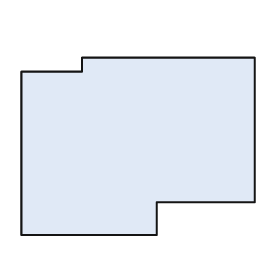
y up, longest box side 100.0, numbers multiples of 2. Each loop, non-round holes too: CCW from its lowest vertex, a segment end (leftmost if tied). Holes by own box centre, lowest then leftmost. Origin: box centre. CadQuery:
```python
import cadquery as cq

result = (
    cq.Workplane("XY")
    .moveTo(-50.0, -38.0)
    .lineTo(8.0, -38.0)
    .lineTo(8.0, -24.0)
    .lineTo(50.0, -24.0)
    .lineTo(50.0, 38.0)
    .lineTo(-24.0, 38.0)
    .lineTo(-24.0, 32.0)
    .lineTo(-50.0, 32.0)
    .close()
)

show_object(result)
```